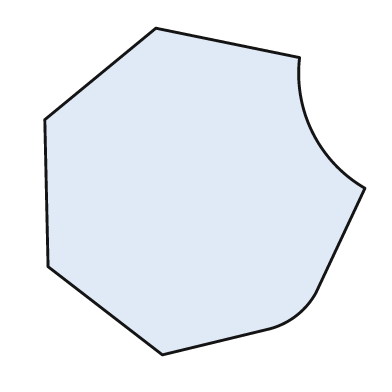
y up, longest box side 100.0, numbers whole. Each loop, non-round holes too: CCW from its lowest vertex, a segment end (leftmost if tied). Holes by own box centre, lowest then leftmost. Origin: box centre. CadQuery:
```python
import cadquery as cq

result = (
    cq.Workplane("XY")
    .moveTo(-13.0, -50.0)
    .lineTo(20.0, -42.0)
    .threePointArc((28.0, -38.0), (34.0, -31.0))
    .lineTo(49.0, 1.0)
    .threePointArc((33.0, 18.0), (29.0, 41.0))
    .lineTo(-15.0, 50.0)
    .lineTo(-49.0, 22.0)
    .lineTo(-48.0, -23.0)
    .close()
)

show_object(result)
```